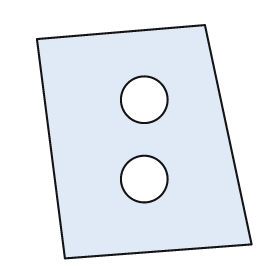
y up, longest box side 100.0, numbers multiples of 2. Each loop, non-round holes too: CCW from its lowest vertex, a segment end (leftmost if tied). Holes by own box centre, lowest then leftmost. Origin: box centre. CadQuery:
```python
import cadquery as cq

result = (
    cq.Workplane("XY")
    .moveTo(-34.0, -50.0)
    .lineTo(46.0, -44.0)
    .lineTo(26.0, 50.0)
    .lineTo(-46.0, 44.0)
    .close()
    .moveTo(0.0, -16.0)
    .circle(10.0)
    .moveTo(0.0, 18.0)
    .circle(10.0)
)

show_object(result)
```